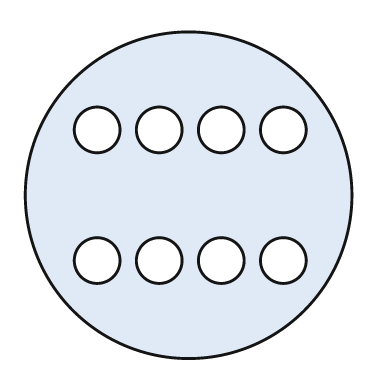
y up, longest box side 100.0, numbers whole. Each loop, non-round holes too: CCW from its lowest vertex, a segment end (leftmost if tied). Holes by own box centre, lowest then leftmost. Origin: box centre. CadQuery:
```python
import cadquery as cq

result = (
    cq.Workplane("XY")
    .moveTo(0.0, 0.0)
    .circle(50.0)
    .moveTo(-28.0, -20.0)
    .circle(7.0)
    .moveTo(-9.0, -20.0)
    .circle(7.0)
    .moveTo(10.0, -20.0)
    .circle(7.0)
    .moveTo(29.0, -20.0)
    .circle(7.0)
    .moveTo(-28.0, 20.0)
    .circle(7.0)
    .moveTo(-9.0, 20.0)
    .circle(7.0)
    .moveTo(10.0, 20.0)
    .circle(7.0)
    .moveTo(29.0, 20.0)
    .circle(7.0)
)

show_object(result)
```